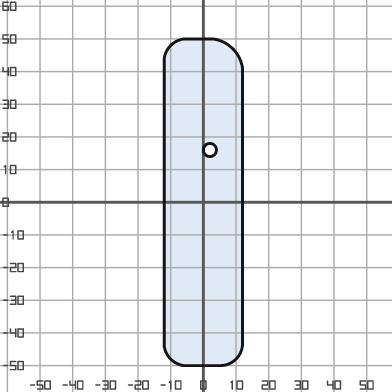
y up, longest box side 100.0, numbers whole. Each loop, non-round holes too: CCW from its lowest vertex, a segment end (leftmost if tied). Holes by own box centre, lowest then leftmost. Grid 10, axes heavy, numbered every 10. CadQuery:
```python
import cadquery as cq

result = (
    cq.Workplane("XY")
    .moveTo(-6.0, -50.0)
    .lineTo(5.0, -50.0)
    .threePointArc((10.0, -48.0), (12.0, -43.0))
    .lineTo(12.0, 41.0)
    .threePointArc((9.0, 47.0), (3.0, 50.0))
    .lineTo(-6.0, 50.0)
    .threePointArc((-10.0, 48.0), (-12.0, 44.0))
    .lineTo(-12.0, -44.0)
    .threePointArc((-10.0, -48.0), (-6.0, -50.0))
    .close()
    .moveTo(2.0, 16.0)
    .circle(2.0)
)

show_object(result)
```